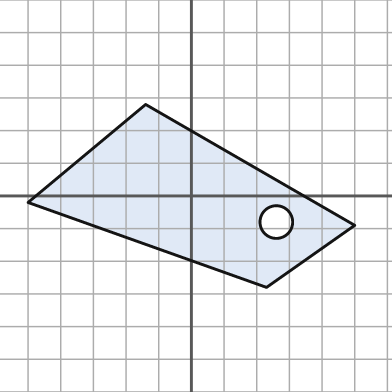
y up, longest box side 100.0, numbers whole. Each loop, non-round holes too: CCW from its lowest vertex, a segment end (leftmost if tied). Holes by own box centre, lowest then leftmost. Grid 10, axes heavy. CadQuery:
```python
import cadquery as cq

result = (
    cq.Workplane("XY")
    .moveTo(23.0, -28.0)
    .lineTo(50.0, -9.0)
    .lineTo(-14.0, 28.0)
    .lineTo(-50.0, -2.0)
    .close()
    .moveTo(26.0, -8.0)
    .circle(5.0)
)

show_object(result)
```